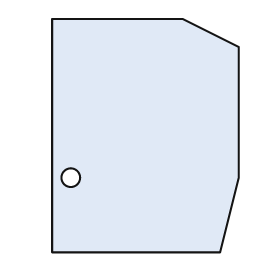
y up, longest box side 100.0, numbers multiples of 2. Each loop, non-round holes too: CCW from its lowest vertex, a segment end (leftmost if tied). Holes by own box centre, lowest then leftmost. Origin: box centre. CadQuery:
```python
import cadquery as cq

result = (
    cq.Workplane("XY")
    .moveTo(-40.0, -50.0)
    .lineTo(32.0, -50.0)
    .lineTo(40.0, -18.0)
    .lineTo(40.0, 38.0)
    .lineTo(16.0, 50.0)
    .lineTo(-40.0, 50.0)
    .close()
    .moveTo(-32.0, -18.0)
    .circle(4.0)
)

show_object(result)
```